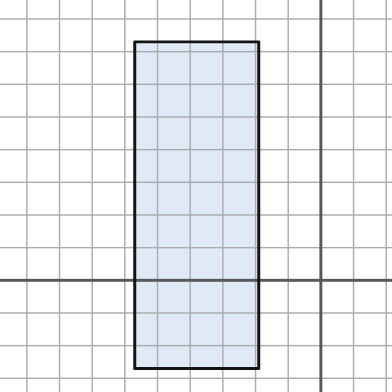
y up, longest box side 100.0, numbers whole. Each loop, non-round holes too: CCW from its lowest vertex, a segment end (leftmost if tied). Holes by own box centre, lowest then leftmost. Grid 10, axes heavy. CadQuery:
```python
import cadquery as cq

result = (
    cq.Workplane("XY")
    .moveTo(-57.0, -27.0)
    .lineTo(-19.0, -27.0)
    .lineTo(-19.0, 73.0)
    .lineTo(-57.0, 73.0)
    .close()
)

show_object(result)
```